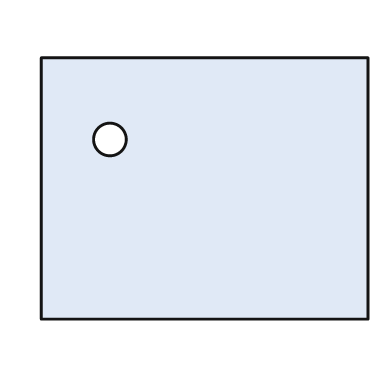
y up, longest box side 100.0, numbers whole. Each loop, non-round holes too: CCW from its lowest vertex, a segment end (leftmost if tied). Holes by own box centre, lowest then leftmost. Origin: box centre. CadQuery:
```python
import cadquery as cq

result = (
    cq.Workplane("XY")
    .moveTo(-50.0, -40.0)
    .lineTo(50.0, -40.0)
    .lineTo(50.0, 40.0)
    .lineTo(-50.0, 40.0)
    .close()
    .moveTo(-29.0, 15.0)
    .circle(5.0)
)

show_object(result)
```